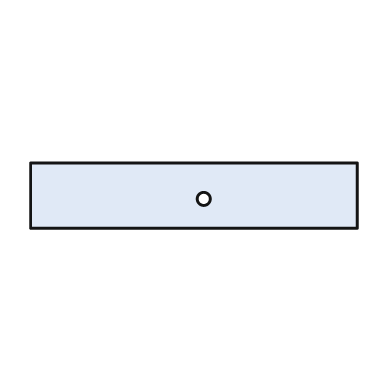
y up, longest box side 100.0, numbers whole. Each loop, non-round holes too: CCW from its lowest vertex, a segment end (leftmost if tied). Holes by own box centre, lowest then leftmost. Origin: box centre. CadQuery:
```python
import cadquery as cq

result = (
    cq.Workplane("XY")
    .moveTo(-50.0, -10.0)
    .lineTo(50.0, -10.0)
    .lineTo(50.0, 10.0)
    .lineTo(-50.0, 10.0)
    .close()
    .moveTo(3.0, -1.0)
    .circle(2.0)
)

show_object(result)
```